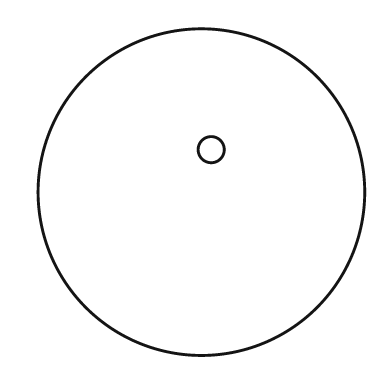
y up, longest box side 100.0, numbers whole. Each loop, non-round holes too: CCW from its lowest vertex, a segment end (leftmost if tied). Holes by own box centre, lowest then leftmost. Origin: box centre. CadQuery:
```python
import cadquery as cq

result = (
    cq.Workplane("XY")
    .moveTo(0.0, 0.0)
    .circle(50.0)
    .moveTo(3.0, 13.0)
    .circle(4.0)
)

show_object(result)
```